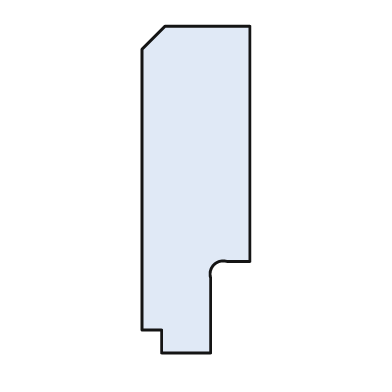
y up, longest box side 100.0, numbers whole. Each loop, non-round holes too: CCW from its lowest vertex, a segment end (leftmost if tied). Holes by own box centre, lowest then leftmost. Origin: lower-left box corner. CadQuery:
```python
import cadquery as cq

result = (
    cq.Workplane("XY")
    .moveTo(6.0, 0.0)
    .lineTo(21.0, 0.0)
    .lineTo(21.0, 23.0)
    .threePointArc((22.0, 27.0), (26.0, 28.0))
    .lineTo(33.0, 28.0)
    .lineTo(33.0, 100.0)
    .lineTo(7.0, 100.0)
    .lineTo(0.0, 93.0)
    .lineTo(0.0, 7.0)
    .lineTo(6.0, 7.0)
    .close()
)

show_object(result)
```